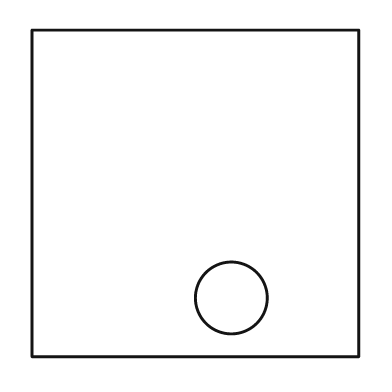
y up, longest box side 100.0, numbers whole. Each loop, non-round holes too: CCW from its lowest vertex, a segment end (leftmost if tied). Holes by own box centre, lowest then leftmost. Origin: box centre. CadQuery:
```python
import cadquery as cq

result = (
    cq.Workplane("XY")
    .moveTo(-50.0, -50.0)
    .lineTo(50.0, -50.0)
    .lineTo(50.0, 50.0)
    .lineTo(-50.0, 50.0)
    .close()
    .moveTo(11.0, -32.0)
    .circle(11.0)
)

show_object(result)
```